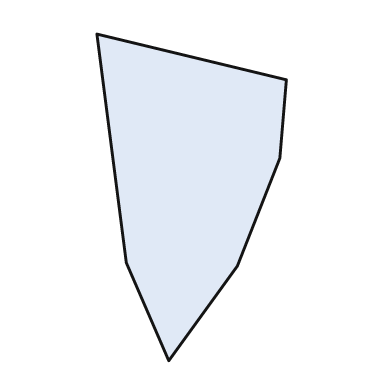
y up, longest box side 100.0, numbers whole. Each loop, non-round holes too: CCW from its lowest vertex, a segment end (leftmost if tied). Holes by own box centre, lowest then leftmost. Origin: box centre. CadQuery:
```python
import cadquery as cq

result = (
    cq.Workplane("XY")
    .moveTo(-7.0, -50.0)
    .lineTo(14.0, -21.0)
    .lineTo(27.0, 12.0)
    .lineTo(29.0, 36.0)
    .lineTo(-29.0, 50.0)
    .lineTo(-20.0, -20.0)
    .close()
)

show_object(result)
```